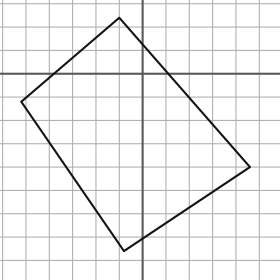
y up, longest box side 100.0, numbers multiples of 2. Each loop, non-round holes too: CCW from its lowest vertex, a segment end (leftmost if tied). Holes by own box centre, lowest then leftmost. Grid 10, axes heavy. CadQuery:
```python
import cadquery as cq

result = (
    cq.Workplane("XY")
    .moveTo(-8.0, -76.0)
    .lineTo(46.0, -40.0)
    .lineTo(-10.0, 24.0)
    .lineTo(-52.0, -12.0)
    .close()
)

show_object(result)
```